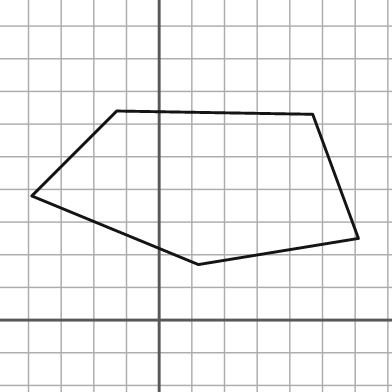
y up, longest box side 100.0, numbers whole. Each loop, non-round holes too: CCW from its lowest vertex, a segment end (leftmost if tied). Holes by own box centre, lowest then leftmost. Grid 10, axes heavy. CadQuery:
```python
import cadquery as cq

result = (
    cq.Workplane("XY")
    .moveTo(12.0, 17.0)
    .lineTo(61.0, 25.0)
    .lineTo(47.0, 63.0)
    .lineTo(-13.0, 64.0)
    .lineTo(-39.0, 38.0)
    .close()
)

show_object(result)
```